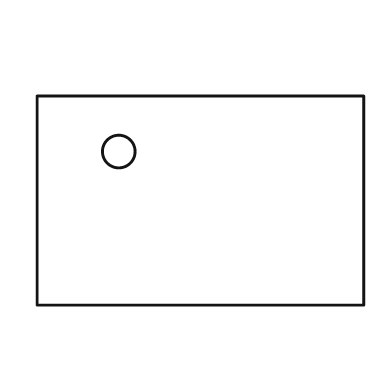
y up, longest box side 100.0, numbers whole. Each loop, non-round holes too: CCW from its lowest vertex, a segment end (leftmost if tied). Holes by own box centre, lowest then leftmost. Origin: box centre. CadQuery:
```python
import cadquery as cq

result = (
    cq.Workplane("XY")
    .moveTo(-50.0, -32.0)
    .lineTo(50.0, -32.0)
    .lineTo(50.0, 32.0)
    .lineTo(-50.0, 32.0)
    .close()
    .moveTo(-25.0, 15.0)
    .circle(5.0)
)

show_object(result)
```